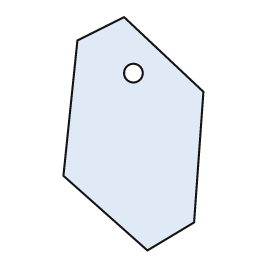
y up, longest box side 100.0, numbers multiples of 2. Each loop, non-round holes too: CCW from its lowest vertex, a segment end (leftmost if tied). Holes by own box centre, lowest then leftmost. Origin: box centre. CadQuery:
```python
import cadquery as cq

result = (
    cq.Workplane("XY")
    .moveTo(6.0, -50.0)
    .lineTo(26.0, -38.0)
    .lineTo(30.0, 18.0)
    .lineTo(-4.0, 50.0)
    .lineTo(-24.0, 40.0)
    .lineTo(-30.0, -18.0)
    .close()
    .moveTo(0.0, 26.0)
    .circle(4.0)
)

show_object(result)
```